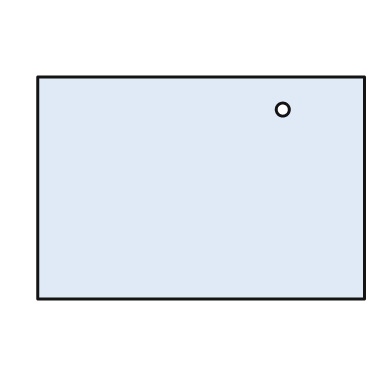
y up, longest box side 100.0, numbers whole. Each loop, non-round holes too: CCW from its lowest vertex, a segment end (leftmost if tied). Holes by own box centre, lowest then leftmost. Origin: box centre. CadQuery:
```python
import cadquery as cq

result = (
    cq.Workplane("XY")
    .moveTo(-50.0, -34.0)
    .lineTo(50.0, -34.0)
    .lineTo(50.0, 34.0)
    .lineTo(-50.0, 34.0)
    .close()
    .moveTo(25.0, 24.0)
    .circle(2.0)
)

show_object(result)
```